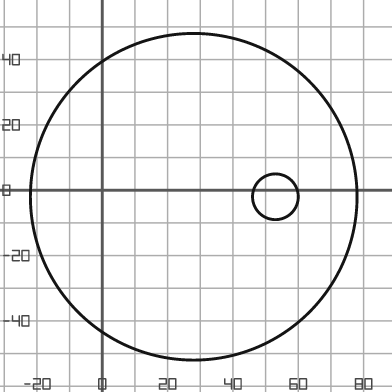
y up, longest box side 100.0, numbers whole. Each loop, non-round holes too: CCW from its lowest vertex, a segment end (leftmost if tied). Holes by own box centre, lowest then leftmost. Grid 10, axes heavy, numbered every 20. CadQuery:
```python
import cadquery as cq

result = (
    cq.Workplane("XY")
    .moveTo(28.0, -2.0)
    .circle(50.0)
    .moveTo(53.0, -2.0)
    .circle(7.0)
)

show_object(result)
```